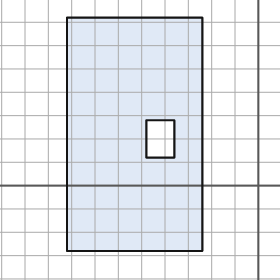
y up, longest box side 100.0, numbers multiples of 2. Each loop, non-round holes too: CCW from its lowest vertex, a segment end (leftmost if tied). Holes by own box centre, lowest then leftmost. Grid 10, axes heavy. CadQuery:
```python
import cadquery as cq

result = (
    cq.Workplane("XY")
    .moveTo(-82.0, -28.0)
    .lineTo(-24.0, -28.0)
    .lineTo(-24.0, 72.0)
    .lineTo(-82.0, 72.0)
    .close()
    .moveTo(-48.0, 12.0)
    .lineTo(-36.0, 12.0)
    .lineTo(-36.0, 28.0)
    .lineTo(-48.0, 28.0)
    .close()
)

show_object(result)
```